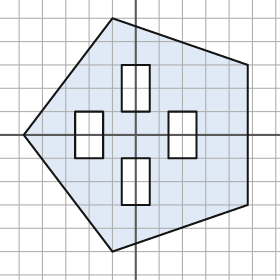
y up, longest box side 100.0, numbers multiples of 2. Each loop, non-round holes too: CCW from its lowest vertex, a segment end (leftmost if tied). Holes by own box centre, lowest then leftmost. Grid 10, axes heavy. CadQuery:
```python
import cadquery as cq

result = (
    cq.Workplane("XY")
    .moveTo(-10.0, -50.0)
    .lineTo(48.0, -30.0)
    .lineTo(48.0, 30.0)
    .lineTo(-10.0, 50.0)
    .lineTo(-48.0, 0.0)
    .close()
    .moveTo(-6.0, -30.0)
    .lineTo(6.0, -30.0)
    .lineTo(6.0, -10.0)
    .lineTo(-6.0, -10.0)
    .close()
    .moveTo(-26.0, -10.0)
    .lineTo(-14.0, -10.0)
    .lineTo(-14.0, 10.0)
    .lineTo(-26.0, 10.0)
    .close()
    .moveTo(14.0, -10.0)
    .lineTo(26.0, -10.0)
    .lineTo(26.0, 10.0)
    .lineTo(14.0, 10.0)
    .close()
    .moveTo(-6.0, 10.0)
    .lineTo(6.0, 10.0)
    .lineTo(6.0, 30.0)
    .lineTo(-6.0, 30.0)
    .close()
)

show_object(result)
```